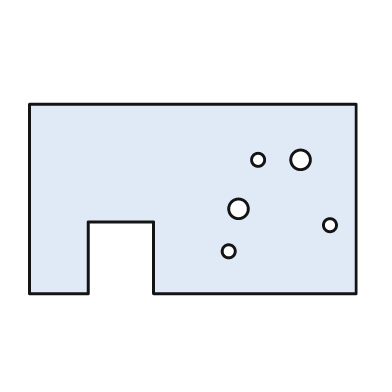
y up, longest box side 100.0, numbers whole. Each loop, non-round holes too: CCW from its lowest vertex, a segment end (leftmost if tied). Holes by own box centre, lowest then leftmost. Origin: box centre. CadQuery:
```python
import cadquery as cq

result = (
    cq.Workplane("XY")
    .moveTo(-50.0, -29.0)
    .lineTo(-32.0, -29.0)
    .lineTo(-32.0, -7.0)
    .lineTo(-12.0, -7.0)
    .lineTo(-12.0, -29.0)
    .lineTo(50.0, -29.0)
    .lineTo(50.0, 29.0)
    .lineTo(-50.0, 29.0)
    .close()
    .moveTo(11.0, -16.0)
    .circle(2.0)
    .moveTo(42.0, -8.0)
    .circle(2.0)
    .moveTo(14.0, -3.0)
    .circle(3.0)
    .moveTo(20.0, 12.0)
    .circle(2.0)
    .moveTo(33.0, 12.0)
    .circle(3.0)
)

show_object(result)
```